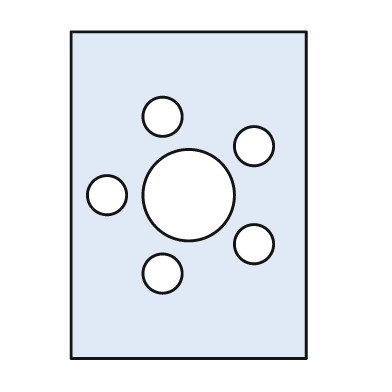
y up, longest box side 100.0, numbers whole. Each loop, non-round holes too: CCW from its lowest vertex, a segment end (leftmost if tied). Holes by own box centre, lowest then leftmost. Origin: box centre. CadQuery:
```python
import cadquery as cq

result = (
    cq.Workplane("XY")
    .moveTo(-36.0, -50.0)
    .lineTo(36.0, -50.0)
    .lineTo(36.0, 50.0)
    .lineTo(-36.0, 50.0)
    .close()
    .moveTo(-8.0, -24.0)
    .circle(6.0)
    .moveTo(20.0, -15.0)
    .circle(6.0)
    .moveTo(-25.0, 0.0)
    .circle(6.0)
    .moveTo(0.0, 0.0)
    .circle(14.0)
    .moveTo(20.0, 15.0)
    .circle(6.0)
    .moveTo(-8.0, 24.0)
    .circle(6.0)
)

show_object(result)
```